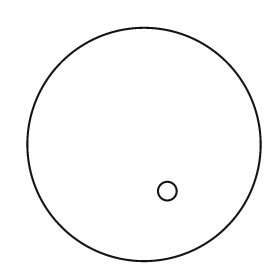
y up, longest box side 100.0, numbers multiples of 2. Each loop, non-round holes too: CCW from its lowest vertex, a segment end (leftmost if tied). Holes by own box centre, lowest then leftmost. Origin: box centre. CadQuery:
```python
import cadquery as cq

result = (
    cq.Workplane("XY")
    .moveTo(0.0, 0.0)
    .circle(50.0)
    .moveTo(10.0, -20.0)
    .circle(4.0)
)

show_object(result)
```